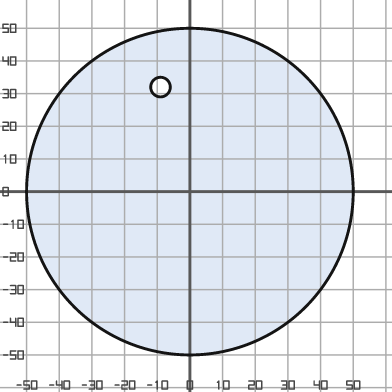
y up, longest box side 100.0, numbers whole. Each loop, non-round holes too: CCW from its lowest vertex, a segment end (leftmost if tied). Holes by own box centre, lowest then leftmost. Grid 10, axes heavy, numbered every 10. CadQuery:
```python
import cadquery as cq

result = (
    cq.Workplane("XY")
    .moveTo(0.0, 0.0)
    .circle(50.0)
    .moveTo(-9.0, 32.0)
    .circle(3.0)
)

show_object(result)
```